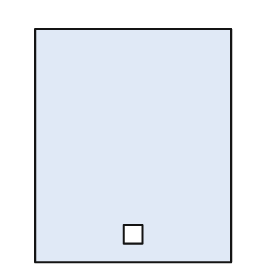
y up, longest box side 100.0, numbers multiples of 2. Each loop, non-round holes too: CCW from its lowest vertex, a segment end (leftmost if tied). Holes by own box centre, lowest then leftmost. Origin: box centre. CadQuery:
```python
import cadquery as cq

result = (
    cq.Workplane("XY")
    .moveTo(-42.0, -50.0)
    .lineTo(42.0, -50.0)
    .lineTo(42.0, 50.0)
    .lineTo(-42.0, 50.0)
    .close()
    .moveTo(-4.0, -42.0)
    .lineTo(4.0, -42.0)
    .lineTo(4.0, -34.0)
    .lineTo(-4.0, -34.0)
    .close()
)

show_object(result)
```